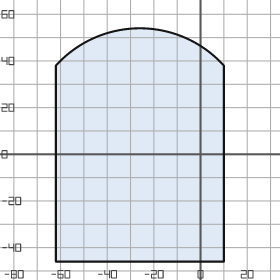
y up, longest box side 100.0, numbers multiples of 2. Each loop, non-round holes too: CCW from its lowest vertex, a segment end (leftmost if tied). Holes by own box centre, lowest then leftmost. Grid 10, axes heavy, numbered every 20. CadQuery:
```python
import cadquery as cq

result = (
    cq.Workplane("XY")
    .moveTo(-62.0, -46.0)
    .lineTo(10.0, -46.0)
    .lineTo(10.0, 38.0)
    .threePointArc((-26.0, 54.0), (-62.0, 38.0))
    .close()
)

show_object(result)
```